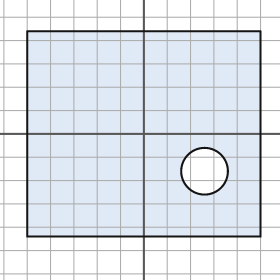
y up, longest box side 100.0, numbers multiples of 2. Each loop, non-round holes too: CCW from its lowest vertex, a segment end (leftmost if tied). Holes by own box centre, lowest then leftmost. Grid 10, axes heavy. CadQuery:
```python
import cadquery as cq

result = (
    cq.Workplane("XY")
    .moveTo(-50.0, -44.0)
    .lineTo(50.0, -44.0)
    .lineTo(50.0, 44.0)
    .lineTo(-50.0, 44.0)
    .close()
    .moveTo(26.0, -16.0)
    .circle(10.0)
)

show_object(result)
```